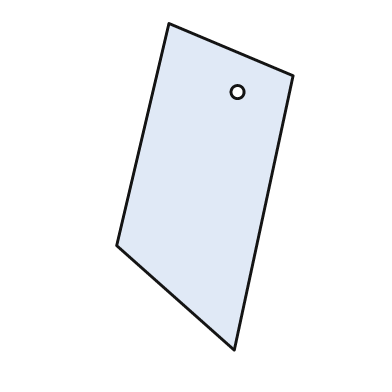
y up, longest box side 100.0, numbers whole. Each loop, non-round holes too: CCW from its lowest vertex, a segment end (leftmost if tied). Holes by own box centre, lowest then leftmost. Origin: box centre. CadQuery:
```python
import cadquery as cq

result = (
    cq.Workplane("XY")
    .moveTo(9.0, -50.0)
    .lineTo(27.0, 34.0)
    .lineTo(-11.0, 50.0)
    .lineTo(-27.0, -18.0)
    .close()
    .moveTo(10.0, 29.0)
    .circle(2.0)
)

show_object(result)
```